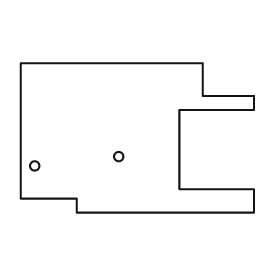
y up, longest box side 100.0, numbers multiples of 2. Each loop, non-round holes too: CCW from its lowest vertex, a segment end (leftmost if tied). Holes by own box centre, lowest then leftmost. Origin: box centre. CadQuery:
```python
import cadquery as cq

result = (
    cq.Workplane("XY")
    .moveTo(-26.0, -32.0)
    .lineTo(50.0, -32.0)
    .lineTo(50.0, -22.0)
    .lineTo(18.0, -22.0)
    .lineTo(18.0, 12.0)
    .lineTo(50.0, 12.0)
    .lineTo(50.0, 18.0)
    .lineTo(28.0, 18.0)
    .lineTo(28.0, 32.0)
    .lineTo(-50.0, 32.0)
    .lineTo(-50.0, -26.0)
    .lineTo(-26.0, -26.0)
    .close()
    .moveTo(-44.0, -12.0)
    .circle(2.0)
    .moveTo(-8.0, -8.0)
    .circle(2.0)
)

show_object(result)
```